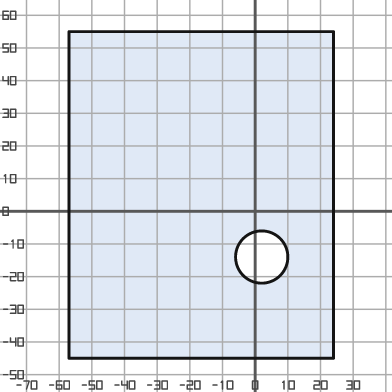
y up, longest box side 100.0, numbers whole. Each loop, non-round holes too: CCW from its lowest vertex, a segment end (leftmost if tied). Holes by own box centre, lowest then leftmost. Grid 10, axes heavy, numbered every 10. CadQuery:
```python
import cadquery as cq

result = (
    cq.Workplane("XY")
    .moveTo(-57.0, -45.0)
    .lineTo(24.0, -45.0)
    .lineTo(24.0, 55.0)
    .lineTo(-57.0, 55.0)
    .close()
    .moveTo(2.0, -14.0)
    .circle(8.0)
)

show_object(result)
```